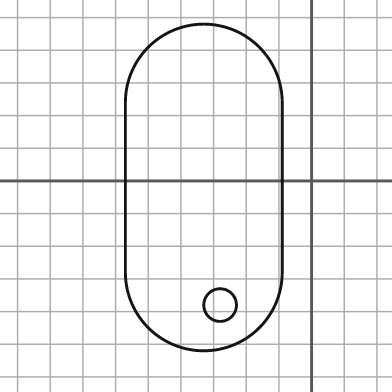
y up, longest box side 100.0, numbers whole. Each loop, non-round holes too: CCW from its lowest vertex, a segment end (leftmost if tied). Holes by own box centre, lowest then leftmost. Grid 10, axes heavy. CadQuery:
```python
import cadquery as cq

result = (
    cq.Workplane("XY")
    .moveTo(-57.0, -28.0)
    .threePointArc((-33.0, -52.0), (-9.0, -28.0))
    .lineTo(-9.0, 24.0)
    .threePointArc((-33.0, 48.0), (-57.0, 24.0))
    .close()
    .moveTo(-28.0, -38.0)
    .circle(5.0)
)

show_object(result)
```